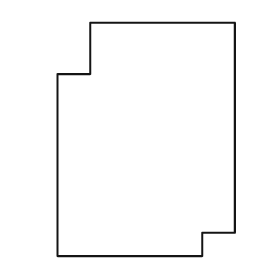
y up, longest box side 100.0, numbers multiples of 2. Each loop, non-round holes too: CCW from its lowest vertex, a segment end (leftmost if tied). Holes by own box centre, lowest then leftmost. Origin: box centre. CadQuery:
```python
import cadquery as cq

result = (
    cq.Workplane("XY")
    .moveTo(-38.0, -50.0)
    .lineTo(24.0, -50.0)
    .lineTo(24.0, -40.0)
    .lineTo(38.0, -40.0)
    .lineTo(38.0, 50.0)
    .lineTo(-24.0, 50.0)
    .lineTo(-24.0, 28.0)
    .lineTo(-38.0, 28.0)
    .close()
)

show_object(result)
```